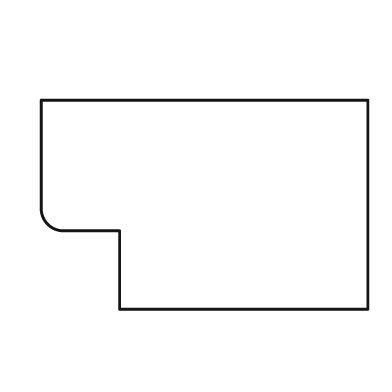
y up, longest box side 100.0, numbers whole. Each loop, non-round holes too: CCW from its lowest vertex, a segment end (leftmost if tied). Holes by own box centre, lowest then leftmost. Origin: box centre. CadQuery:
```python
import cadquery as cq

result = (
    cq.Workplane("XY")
    .moveTo(-26.0, -32.0)
    .lineTo(50.0, -32.0)
    .lineTo(50.0, 32.0)
    .lineTo(-50.0, 32.0)
    .lineTo(-50.0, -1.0)
    .threePointArc((-48.0, -6.0), (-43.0, -8.0))
    .lineTo(-26.0, -8.0)
    .close()
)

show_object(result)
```